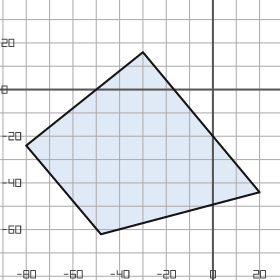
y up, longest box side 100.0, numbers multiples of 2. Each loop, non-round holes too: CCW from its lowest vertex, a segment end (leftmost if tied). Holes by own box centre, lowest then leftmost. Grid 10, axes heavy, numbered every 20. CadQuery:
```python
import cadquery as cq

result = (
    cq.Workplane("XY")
    .moveTo(-48.0, -62.0)
    .lineTo(20.0, -44.0)
    .lineTo(-30.0, 16.0)
    .lineTo(-80.0, -24.0)
    .close()
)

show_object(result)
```